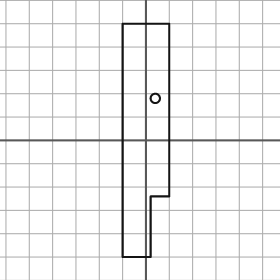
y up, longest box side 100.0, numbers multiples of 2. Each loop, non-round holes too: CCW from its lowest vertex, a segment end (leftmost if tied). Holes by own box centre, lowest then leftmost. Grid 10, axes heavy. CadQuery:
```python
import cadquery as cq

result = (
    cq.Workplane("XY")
    .moveTo(-10.0, -50.0)
    .lineTo(2.0, -50.0)
    .lineTo(2.0, -24.0)
    .lineTo(10.0, -24.0)
    .lineTo(10.0, 50.0)
    .lineTo(-10.0, 50.0)
    .close()
    .moveTo(4.0, 18.0)
    .circle(2.0)
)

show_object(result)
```